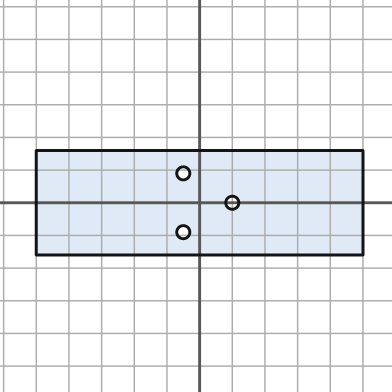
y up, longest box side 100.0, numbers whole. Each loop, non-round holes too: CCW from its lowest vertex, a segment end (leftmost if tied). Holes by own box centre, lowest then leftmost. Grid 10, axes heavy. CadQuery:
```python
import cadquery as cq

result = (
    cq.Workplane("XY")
    .moveTo(-50.0, -16.0)
    .lineTo(50.0, -16.0)
    .lineTo(50.0, 16.0)
    .lineTo(-50.0, 16.0)
    .close()
    .moveTo(-5.0, -9.0)
    .circle(2.0)
    .moveTo(10.0, 0.0)
    .circle(2.0)
    .moveTo(-5.0, 9.0)
    .circle(2.0)
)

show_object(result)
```